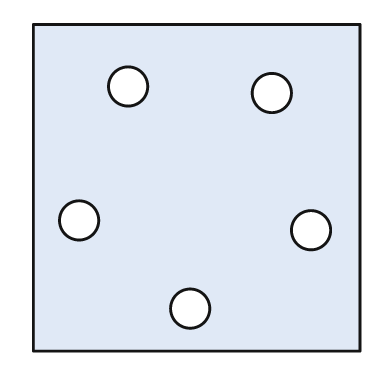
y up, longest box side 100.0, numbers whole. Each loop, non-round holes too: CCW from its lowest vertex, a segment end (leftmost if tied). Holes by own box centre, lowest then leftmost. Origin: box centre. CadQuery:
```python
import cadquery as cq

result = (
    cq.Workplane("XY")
    .moveTo(-50.0, -50.0)
    .lineTo(50.0, -50.0)
    .lineTo(50.0, 50.0)
    .lineTo(-50.0, 50.0)
    .close()
    .moveTo(-2.0, -37.0)
    .circle(6.0)
    .moveTo(35.0, -13.0)
    .circle(6.0)
    .moveTo(-36.0, -10.0)
    .circle(6.0)
    .moveTo(23.0, 29.0)
    .circle(6.0)
    .moveTo(-21.0, 31.0)
    .circle(6.0)
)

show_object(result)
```